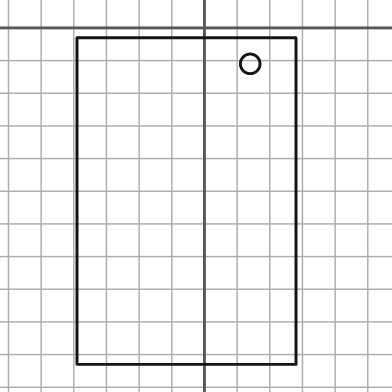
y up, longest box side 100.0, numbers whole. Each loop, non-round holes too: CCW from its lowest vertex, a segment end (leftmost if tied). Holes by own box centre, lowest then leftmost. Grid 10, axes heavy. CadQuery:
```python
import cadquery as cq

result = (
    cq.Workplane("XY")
    .moveTo(-39.0, -103.0)
    .lineTo(28.0, -103.0)
    .lineTo(28.0, -3.0)
    .lineTo(-39.0, -3.0)
    .close()
    .moveTo(14.0, -11.0)
    .circle(3.0)
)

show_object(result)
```